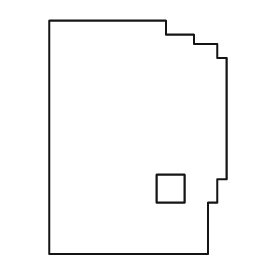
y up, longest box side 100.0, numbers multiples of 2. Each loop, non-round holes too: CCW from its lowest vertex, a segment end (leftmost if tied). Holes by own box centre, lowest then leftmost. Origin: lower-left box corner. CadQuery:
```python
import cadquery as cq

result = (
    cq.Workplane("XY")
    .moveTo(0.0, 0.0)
    .lineTo(68.0, 0.0)
    .lineTo(68.0, 22.0)
    .lineTo(72.0, 22.0)
    .lineTo(72.0, 32.0)
    .lineTo(76.0, 32.0)
    .lineTo(76.0, 84.0)
    .lineTo(72.0, 84.0)
    .lineTo(72.0, 90.0)
    .lineTo(62.0, 90.0)
    .lineTo(62.0, 94.0)
    .lineTo(50.0, 94.0)
    .lineTo(50.0, 100.0)
    .lineTo(0.0, 100.0)
    .close()
    .moveTo(46.0, 22.0)
    .lineTo(58.0, 22.0)
    .lineTo(58.0, 34.0)
    .lineTo(46.0, 34.0)
    .close()
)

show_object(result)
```